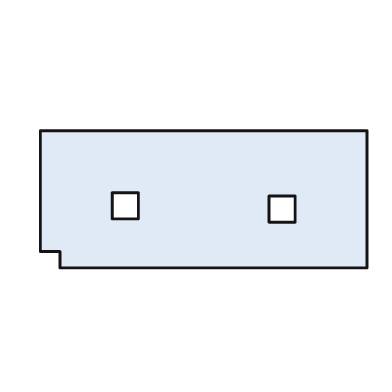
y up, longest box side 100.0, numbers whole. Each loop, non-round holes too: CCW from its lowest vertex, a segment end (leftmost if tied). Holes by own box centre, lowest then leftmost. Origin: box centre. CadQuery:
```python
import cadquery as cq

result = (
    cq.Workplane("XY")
    .moveTo(-44.0, -21.0)
    .lineTo(50.0, -21.0)
    .lineTo(50.0, 21.0)
    .lineTo(-50.0, 21.0)
    .lineTo(-50.0, -16.0)
    .lineTo(-44.0, -16.0)
    .close()
    .moveTo(20.0, -7.0)
    .lineTo(28.0, -7.0)
    .lineTo(28.0, 1.0)
    .lineTo(20.0, 1.0)
    .close()
    .moveTo(-28.0, -6.0)
    .lineTo(-20.0, -6.0)
    .lineTo(-20.0, 2.0)
    .lineTo(-28.0, 2.0)
    .close()
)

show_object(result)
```